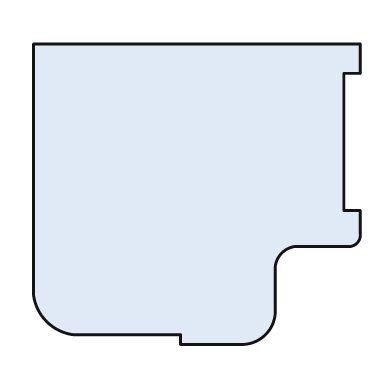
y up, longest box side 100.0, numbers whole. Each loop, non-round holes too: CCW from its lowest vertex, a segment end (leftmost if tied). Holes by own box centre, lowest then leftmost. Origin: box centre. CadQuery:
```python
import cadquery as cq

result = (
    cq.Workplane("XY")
    .moveTo(-5.0, -46.0)
    .lineTo(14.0, -46.0)
    .threePointArc((21.0, -43.0), (24.0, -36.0))
    .lineTo(24.0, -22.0)
    .threePointArc((26.0, -18.0), (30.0, -16.0))
    .lineTo(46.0, -16.0)
    .threePointArc((49.0, -15.0), (50.0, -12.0))
    .lineTo(50.0, -5.0)
    .lineTo(45.0, -5.0)
    .lineTo(45.0, 37.0)
    .lineTo(50.0, 37.0)
    .lineTo(50.0, 46.0)
    .lineTo(-50.0, 46.0)
    .lineTo(-50.0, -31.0)
    .threePointArc((-46.0, -39.0), (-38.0, -43.0))
    .lineTo(-5.0, -43.0)
    .close()
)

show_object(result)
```